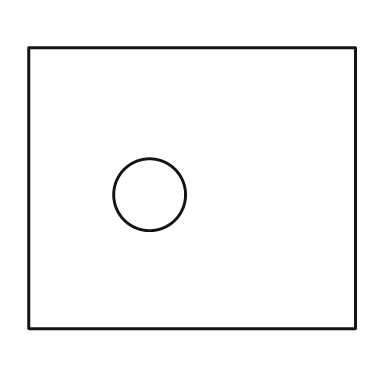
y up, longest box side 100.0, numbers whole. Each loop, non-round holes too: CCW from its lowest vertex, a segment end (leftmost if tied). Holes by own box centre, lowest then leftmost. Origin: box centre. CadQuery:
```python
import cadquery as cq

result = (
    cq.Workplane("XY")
    .moveTo(-50.0, -43.0)
    .lineTo(50.0, -43.0)
    .lineTo(50.0, 43.0)
    .lineTo(-50.0, 43.0)
    .close()
    .moveTo(-13.0, -2.0)
    .circle(11.0)
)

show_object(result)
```